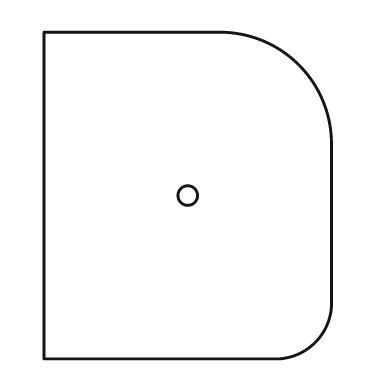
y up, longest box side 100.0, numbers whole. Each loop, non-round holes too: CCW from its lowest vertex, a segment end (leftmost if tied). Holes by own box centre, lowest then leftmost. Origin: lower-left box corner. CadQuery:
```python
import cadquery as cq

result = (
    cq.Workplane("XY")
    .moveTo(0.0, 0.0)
    .lineTo(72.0, 0.0)
    .threePointArc((83.0, 5.0), (88.0, 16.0))
    .lineTo(88.0, 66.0)
    .threePointArc((78.0, 90.0), (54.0, 100.0))
    .lineTo(0.0, 100.0)
    .close()
    .moveTo(44.0, 50.0)
    .circle(3.0)
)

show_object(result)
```